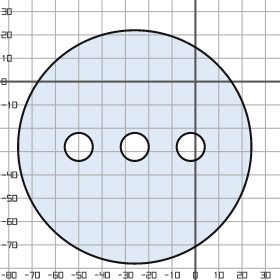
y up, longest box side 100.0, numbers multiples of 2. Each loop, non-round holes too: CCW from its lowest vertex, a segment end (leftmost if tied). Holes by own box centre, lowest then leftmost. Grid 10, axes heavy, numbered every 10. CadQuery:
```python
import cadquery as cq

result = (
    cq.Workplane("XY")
    .moveTo(-26.0, -28.0)
    .circle(50.0)
    .moveTo(-50.0, -28.0)
    .circle(6.0)
    .moveTo(-26.0, -28.0)
    .circle(6.0)
    .moveTo(-2.0, -28.0)
    .circle(6.0)
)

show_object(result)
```